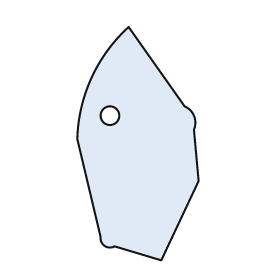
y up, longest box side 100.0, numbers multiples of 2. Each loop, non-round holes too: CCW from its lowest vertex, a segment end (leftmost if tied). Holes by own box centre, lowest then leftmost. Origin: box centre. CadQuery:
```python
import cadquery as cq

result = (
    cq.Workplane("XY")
    .moveTo(10.0, -50.0)
    .lineTo(26.0, -16.0)
    .lineTo(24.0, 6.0)
    .threePointArc((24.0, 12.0), (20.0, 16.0))
    .lineTo(-4.0, 50.0)
    .threePointArc((-20.0, 28.0), (-26.0, 2.0))
    .lineTo(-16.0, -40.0)
    .threePointArc((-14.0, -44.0), (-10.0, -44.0))
    .close()
    .moveTo(-12.0, 12.0)
    .circle(4.0)
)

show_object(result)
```